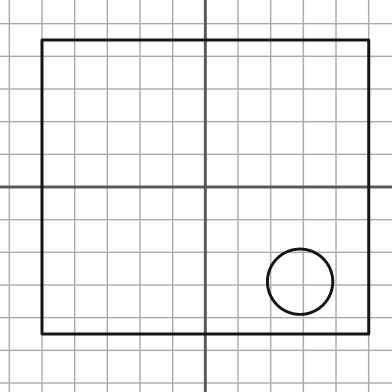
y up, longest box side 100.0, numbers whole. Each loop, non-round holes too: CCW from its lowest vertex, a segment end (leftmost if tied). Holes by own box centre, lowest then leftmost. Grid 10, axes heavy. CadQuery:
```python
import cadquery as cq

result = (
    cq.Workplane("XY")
    .moveTo(-50.0, -45.0)
    .lineTo(50.0, -45.0)
    .lineTo(50.0, 45.0)
    .lineTo(-50.0, 45.0)
    .close()
    .moveTo(29.0, -29.0)
    .circle(10.0)
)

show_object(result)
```